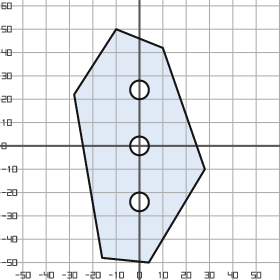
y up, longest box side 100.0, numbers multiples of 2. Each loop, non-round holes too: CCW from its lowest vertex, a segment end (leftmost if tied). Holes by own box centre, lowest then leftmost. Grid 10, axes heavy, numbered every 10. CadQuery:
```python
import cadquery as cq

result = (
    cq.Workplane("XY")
    .moveTo(4.0, -50.0)
    .lineTo(28.0, -10.0)
    .lineTo(10.0, 42.0)
    .lineTo(-10.0, 50.0)
    .lineTo(-28.0, 22.0)
    .lineTo(-16.0, -48.0)
    .close()
    .moveTo(0.0, -24.0)
    .circle(4.0)
    .moveTo(0.0, 0.0)
    .circle(4.0)
    .moveTo(0.0, 24.0)
    .circle(4.0)
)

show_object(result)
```